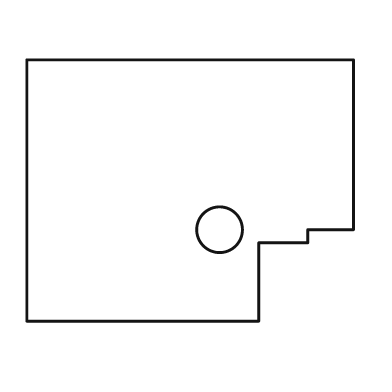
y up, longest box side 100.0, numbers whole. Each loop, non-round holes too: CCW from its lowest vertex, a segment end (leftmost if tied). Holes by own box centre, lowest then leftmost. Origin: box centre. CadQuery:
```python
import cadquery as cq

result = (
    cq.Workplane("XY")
    .moveTo(-50.0, -40.0)
    .lineTo(21.0, -40.0)
    .lineTo(21.0, -16.0)
    .lineTo(36.0, -16.0)
    .lineTo(36.0, -12.0)
    .lineTo(50.0, -12.0)
    .lineTo(50.0, 40.0)
    .lineTo(-50.0, 40.0)
    .close()
    .moveTo(9.0, -12.0)
    .circle(7.0)
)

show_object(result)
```